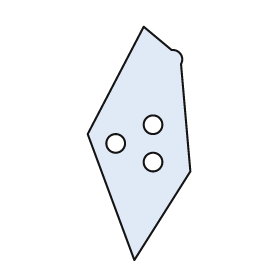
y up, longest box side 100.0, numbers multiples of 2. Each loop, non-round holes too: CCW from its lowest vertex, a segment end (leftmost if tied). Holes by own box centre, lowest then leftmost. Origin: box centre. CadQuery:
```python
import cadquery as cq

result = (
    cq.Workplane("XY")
    .moveTo(-2.0, -50.0)
    .lineTo(22.0, -12.0)
    .lineTo(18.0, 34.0)
    .threePointArc((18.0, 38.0), (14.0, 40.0))
    .lineTo(2.0, 50.0)
    .lineTo(-22.0, 4.0)
    .close()
    .moveTo(6.0, -8.0)
    .circle(4.0)
    .moveTo(-10.0, 0.0)
    .circle(4.0)
    .moveTo(6.0, 8.0)
    .circle(4.0)
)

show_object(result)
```